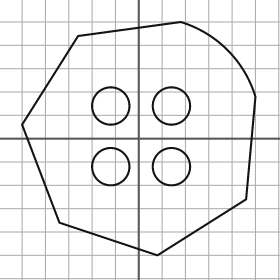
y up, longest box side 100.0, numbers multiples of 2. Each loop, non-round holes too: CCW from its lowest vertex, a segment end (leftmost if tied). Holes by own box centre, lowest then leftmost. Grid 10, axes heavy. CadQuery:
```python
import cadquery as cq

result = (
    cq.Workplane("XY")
    .moveTo(8.0, -50.0)
    .lineTo(46.0, -26.0)
    .lineTo(50.0, 18.0)
    .threePointArc((38.0, 38.0), (18.0, 50.0))
    .lineTo(-26.0, 44.0)
    .lineTo(-50.0, 6.0)
    .lineTo(-34.0, -36.0)
    .close()
    .moveTo(-12.0, -12.0)
    .circle(8.0)
    .moveTo(14.0, -12.0)
    .circle(8.0)
    .moveTo(-12.0, 14.0)
    .circle(8.0)
    .moveTo(14.0, 14.0)
    .circle(8.0)
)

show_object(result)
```